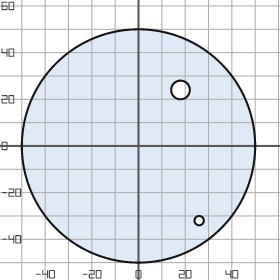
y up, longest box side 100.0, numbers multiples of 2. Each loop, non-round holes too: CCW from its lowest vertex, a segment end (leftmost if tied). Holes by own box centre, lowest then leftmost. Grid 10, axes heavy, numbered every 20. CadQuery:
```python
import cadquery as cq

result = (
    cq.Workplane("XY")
    .moveTo(0.0, 0.0)
    .circle(50.0)
    .moveTo(26.0, -32.0)
    .circle(2.0)
    .moveTo(18.0, 24.0)
    .circle(4.0)
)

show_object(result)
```